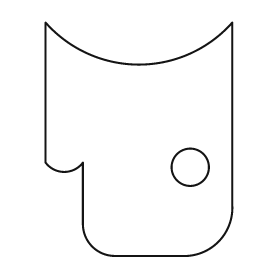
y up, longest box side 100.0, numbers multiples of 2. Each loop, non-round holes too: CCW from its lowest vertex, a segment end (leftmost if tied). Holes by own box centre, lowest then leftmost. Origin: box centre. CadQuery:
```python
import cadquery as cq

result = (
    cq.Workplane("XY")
    .moveTo(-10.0, -50.0)
    .lineTo(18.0, -50.0)
    .threePointArc((34.0, -44.0), (40.0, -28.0))
    .lineTo(40.0, 50.0)
    .threePointArc((0.0, 32.0), (-40.0, 50.0))
    .lineTo(-40.0, -10.0)
    .threePointArc((-32.0, -14.0), (-24.0, -10.0))
    .lineTo(-24.0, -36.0)
    .threePointArc((-20.0, -46.0), (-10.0, -50.0))
    .close()
    .moveTo(22.0, -12.0)
    .circle(8.0)
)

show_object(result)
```